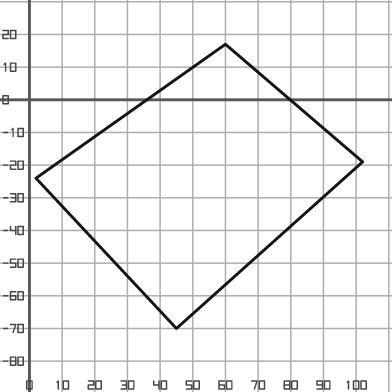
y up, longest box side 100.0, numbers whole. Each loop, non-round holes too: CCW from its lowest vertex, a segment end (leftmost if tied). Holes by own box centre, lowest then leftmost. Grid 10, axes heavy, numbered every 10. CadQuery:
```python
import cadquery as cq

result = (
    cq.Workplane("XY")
    .moveTo(45.0, -70.0)
    .lineTo(102.0, -19.0)
    .lineTo(60.0, 17.0)
    .lineTo(2.0, -24.0)
    .close()
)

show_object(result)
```